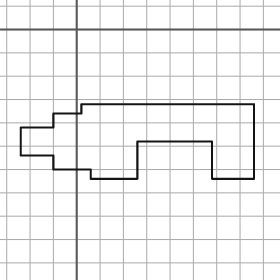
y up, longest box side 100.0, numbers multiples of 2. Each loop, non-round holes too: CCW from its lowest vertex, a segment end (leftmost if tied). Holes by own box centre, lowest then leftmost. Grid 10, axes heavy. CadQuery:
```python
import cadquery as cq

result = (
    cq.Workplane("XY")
    .moveTo(6.0, -64.0)
    .lineTo(26.0, -64.0)
    .lineTo(26.0, -48.0)
    .lineTo(58.0, -48.0)
    .lineTo(58.0, -64.0)
    .lineTo(76.0, -64.0)
    .lineTo(76.0, -32.0)
    .lineTo(2.0, -32.0)
    .lineTo(2.0, -36.0)
    .lineTo(-10.0, -36.0)
    .lineTo(-10.0, -42.0)
    .lineTo(-24.0, -42.0)
    .lineTo(-24.0, -54.0)
    .lineTo(-10.0, -54.0)
    .lineTo(-10.0, -60.0)
    .lineTo(6.0, -60.0)
    .close()
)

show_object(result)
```